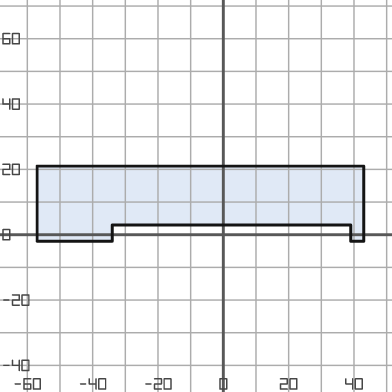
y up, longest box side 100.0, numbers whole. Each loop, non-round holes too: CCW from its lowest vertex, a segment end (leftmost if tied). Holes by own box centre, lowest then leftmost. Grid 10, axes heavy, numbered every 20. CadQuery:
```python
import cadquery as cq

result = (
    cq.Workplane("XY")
    .moveTo(-57.0, -2.0)
    .lineTo(-34.0, -2.0)
    .lineTo(-34.0, 3.0)
    .lineTo(39.0, 3.0)
    .lineTo(39.0, -2.0)
    .lineTo(43.0, -2.0)
    .lineTo(43.0, 21.0)
    .lineTo(-57.0, 21.0)
    .close()
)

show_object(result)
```